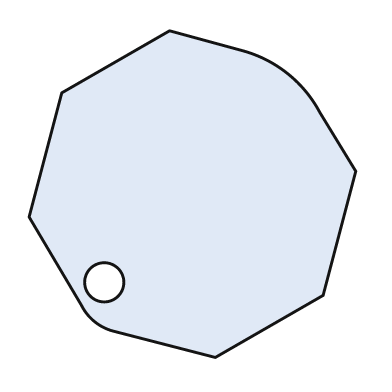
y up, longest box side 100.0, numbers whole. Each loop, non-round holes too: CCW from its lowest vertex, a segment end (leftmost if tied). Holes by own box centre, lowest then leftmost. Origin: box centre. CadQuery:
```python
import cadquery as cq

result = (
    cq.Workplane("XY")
    .moveTo(7.0, -50.0)
    .lineTo(40.0, -31.0)
    .lineTo(50.0, 7.0)
    .lineTo(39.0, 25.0)
    .threePointArc((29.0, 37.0), (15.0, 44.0))
    .lineTo(-7.0, 50.0)
    .lineTo(-40.0, 31.0)
    .lineTo(-50.0, -7.0)
    .lineTo(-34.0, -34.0)
    .threePointArc((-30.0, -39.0), (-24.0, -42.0))
    .close()
    .moveTo(-27.0, -27.0)
    .circle(6.0)
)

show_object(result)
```